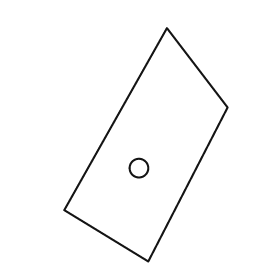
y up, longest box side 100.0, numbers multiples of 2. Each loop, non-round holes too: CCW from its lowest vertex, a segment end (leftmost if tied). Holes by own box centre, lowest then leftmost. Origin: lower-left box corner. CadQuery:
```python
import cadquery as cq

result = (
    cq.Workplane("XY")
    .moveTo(36.0, 0.0)
    .lineTo(70.0, 66.0)
    .lineTo(44.0, 100.0)
    .lineTo(0.0, 22.0)
    .close()
    .moveTo(32.0, 40.0)
    .circle(4.0)
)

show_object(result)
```